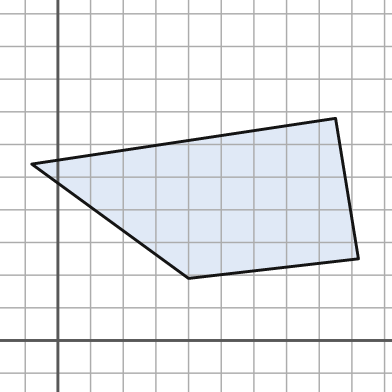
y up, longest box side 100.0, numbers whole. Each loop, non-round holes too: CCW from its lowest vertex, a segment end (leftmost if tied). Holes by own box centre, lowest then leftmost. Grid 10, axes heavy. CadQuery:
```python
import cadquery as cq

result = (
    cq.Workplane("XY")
    .moveTo(40.0, 19.0)
    .lineTo(92.0, 25.0)
    .lineTo(85.0, 68.0)
    .lineTo(-8.0, 54.0)
    .close()
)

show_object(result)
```